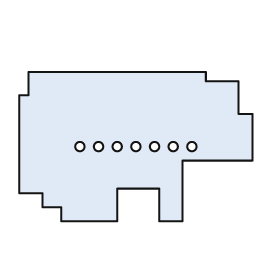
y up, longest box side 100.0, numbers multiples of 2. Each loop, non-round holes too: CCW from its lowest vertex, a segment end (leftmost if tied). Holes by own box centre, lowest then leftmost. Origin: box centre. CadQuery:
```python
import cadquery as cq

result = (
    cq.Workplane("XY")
    .moveTo(-32.0, -32.0)
    .lineTo(-8.0, -32.0)
    .lineTo(-8.0, -18.0)
    .lineTo(10.0, -18.0)
    .lineTo(10.0, -32.0)
    .lineTo(20.0, -32.0)
    .lineTo(20.0, -6.0)
    .lineTo(50.0, -6.0)
    .lineTo(50.0, 14.0)
    .lineTo(44.0, 14.0)
    .lineTo(44.0, 28.0)
    .lineTo(30.0, 28.0)
    .lineTo(30.0, 32.0)
    .lineTo(-46.0, 32.0)
    .lineTo(-46.0, 22.0)
    .lineTo(-50.0, 22.0)
    .lineTo(-50.0, -20.0)
    .lineTo(-40.0, -20.0)
    .lineTo(-40.0, -26.0)
    .lineTo(-32.0, -26.0)
    .close()
    .moveTo(-24.0, 0.0)
    .circle(2.0)
    .moveTo(-16.0, 0.0)
    .circle(2.0)
    .moveTo(-8.0, 0.0)
    .circle(2.0)
    .moveTo(0.0, 0.0)
    .circle(2.0)
    .moveTo(8.0, 0.0)
    .circle(2.0)
    .moveTo(16.0, 0.0)
    .circle(2.0)
    .moveTo(24.0, 0.0)
    .circle(2.0)
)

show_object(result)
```